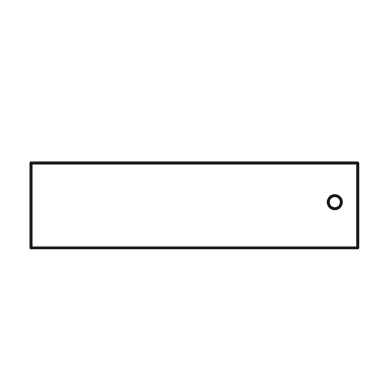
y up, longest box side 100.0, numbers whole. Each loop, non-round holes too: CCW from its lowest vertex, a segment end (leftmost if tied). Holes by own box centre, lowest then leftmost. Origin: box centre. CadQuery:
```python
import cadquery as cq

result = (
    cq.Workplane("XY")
    .moveTo(-50.0, -13.0)
    .lineTo(50.0, -13.0)
    .lineTo(50.0, 13.0)
    .lineTo(-50.0, 13.0)
    .close()
    .moveTo(43.0, 1.0)
    .circle(2.0)
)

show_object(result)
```